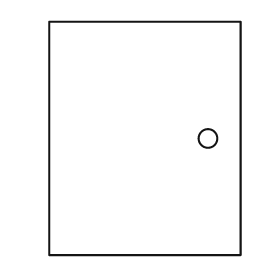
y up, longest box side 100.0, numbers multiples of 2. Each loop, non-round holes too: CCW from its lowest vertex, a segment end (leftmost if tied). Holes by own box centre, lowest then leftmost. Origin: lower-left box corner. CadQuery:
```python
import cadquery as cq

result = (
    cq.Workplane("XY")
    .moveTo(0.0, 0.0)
    .lineTo(82.0, 0.0)
    .lineTo(82.0, 100.0)
    .lineTo(0.0, 100.0)
    .close()
    .moveTo(68.0, 50.0)
    .circle(4.0)
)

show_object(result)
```